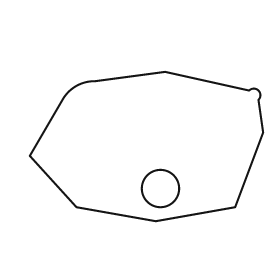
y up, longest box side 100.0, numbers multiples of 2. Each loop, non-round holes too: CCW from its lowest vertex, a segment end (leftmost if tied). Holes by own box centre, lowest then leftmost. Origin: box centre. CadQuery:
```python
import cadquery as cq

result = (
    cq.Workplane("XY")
    .moveTo(4.0, -32.0)
    .lineTo(38.0, -26.0)
    .lineTo(50.0, 6.0)
    .lineTo(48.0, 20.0)
    .threePointArc((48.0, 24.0), (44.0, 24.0))
    .lineTo(8.0, 32.0)
    .lineTo(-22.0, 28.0)
    .threePointArc((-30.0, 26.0), (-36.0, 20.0))
    .lineTo(-50.0, -4.0)
    .lineTo(-30.0, -26.0)
    .close()
    .moveTo(6.0, -18.0)
    .circle(8.0)
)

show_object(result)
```